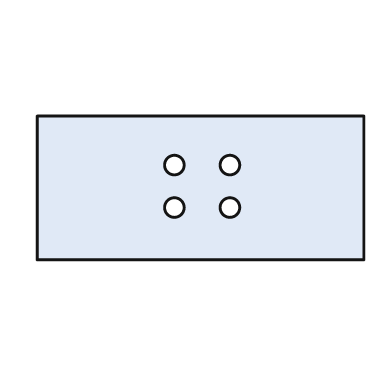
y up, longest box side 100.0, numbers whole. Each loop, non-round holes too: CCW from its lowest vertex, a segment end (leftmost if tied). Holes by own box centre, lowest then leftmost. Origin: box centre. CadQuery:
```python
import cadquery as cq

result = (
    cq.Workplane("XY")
    .moveTo(-50.0, -22.0)
    .lineTo(50.0, -22.0)
    .lineTo(50.0, 22.0)
    .lineTo(-50.0, 22.0)
    .close()
    .moveTo(-8.0, -6.0)
    .circle(3.0)
    .moveTo(9.0, -6.0)
    .circle(3.0)
    .moveTo(-8.0, 7.0)
    .circle(3.0)
    .moveTo(9.0, 7.0)
    .circle(3.0)
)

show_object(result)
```